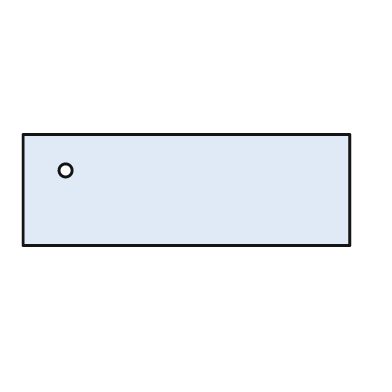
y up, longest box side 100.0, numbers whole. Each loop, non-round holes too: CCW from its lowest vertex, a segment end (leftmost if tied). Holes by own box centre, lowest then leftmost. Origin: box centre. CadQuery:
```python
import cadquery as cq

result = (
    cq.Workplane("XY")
    .moveTo(-50.0, -17.0)
    .lineTo(50.0, -17.0)
    .lineTo(50.0, 17.0)
    .lineTo(-50.0, 17.0)
    .close()
    .moveTo(-37.0, 6.0)
    .circle(2.0)
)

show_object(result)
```